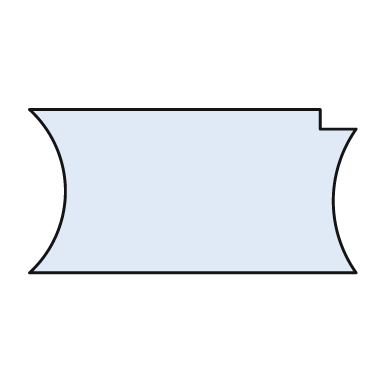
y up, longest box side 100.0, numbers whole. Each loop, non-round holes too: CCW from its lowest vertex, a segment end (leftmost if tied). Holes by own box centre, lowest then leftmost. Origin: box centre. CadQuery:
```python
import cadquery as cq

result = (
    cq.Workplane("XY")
    .moveTo(-50.0, -25.0)
    .lineTo(50.0, -25.0)
    .threePointArc((43.0, -3.0), (50.0, 19.0))
    .lineTo(39.0, 19.0)
    .lineTo(39.0, 25.0)
    .lineTo(-50.0, 25.0)
    .threePointArc((-39.0, 0.0), (-50.0, -25.0))
    .close()
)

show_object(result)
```